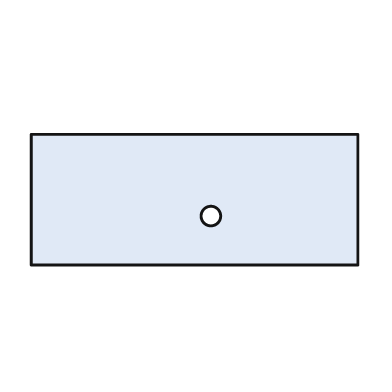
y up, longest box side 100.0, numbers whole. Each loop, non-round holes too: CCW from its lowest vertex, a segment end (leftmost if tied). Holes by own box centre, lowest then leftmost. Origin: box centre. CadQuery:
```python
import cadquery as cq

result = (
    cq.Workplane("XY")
    .moveTo(-50.0, -20.0)
    .lineTo(50.0, -20.0)
    .lineTo(50.0, 20.0)
    .lineTo(-50.0, 20.0)
    .close()
    .moveTo(5.0, -5.0)
    .circle(3.0)
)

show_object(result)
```